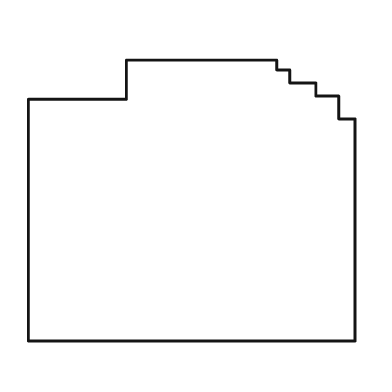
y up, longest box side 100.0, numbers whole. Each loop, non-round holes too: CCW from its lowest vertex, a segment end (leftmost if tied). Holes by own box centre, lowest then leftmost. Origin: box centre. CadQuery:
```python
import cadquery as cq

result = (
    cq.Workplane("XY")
    .moveTo(-50.0, -43.0)
    .lineTo(50.0, -43.0)
    .lineTo(50.0, 25.0)
    .lineTo(45.0, 25.0)
    .lineTo(45.0, 32.0)
    .lineTo(38.0, 32.0)
    .lineTo(38.0, 36.0)
    .lineTo(30.0, 36.0)
    .lineTo(30.0, 40.0)
    .lineTo(26.0, 40.0)
    .lineTo(26.0, 43.0)
    .lineTo(-20.0, 43.0)
    .lineTo(-20.0, 31.0)
    .lineTo(-50.0, 31.0)
    .close()
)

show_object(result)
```